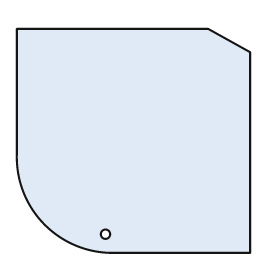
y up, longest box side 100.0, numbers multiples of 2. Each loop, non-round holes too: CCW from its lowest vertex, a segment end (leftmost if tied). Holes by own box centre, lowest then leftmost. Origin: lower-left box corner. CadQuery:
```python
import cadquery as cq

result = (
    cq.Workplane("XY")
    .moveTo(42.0, 0.0)
    .lineTo(100.0, 0.0)
    .lineTo(100.0, 86.0)
    .lineTo(82.0, 96.0)
    .lineTo(0.0, 96.0)
    .lineTo(0.0, 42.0)
    .threePointArc((12.0, 12.0), (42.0, 0.0))
    .close()
    .moveTo(38.0, 8.0)
    .circle(2.0)
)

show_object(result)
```